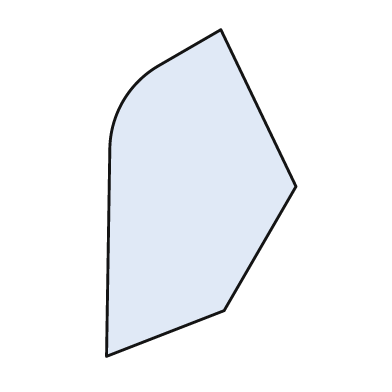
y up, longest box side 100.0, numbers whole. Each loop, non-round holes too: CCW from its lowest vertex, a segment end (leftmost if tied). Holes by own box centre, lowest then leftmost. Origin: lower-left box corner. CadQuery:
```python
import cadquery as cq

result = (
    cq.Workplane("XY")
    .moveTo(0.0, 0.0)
    .lineTo(36.0, 14.0)
    .lineTo(58.0, 52.0)
    .lineTo(35.0, 100.0)
    .lineTo(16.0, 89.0)
    .threePointArc((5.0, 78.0), (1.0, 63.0))
    .close()
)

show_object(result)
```